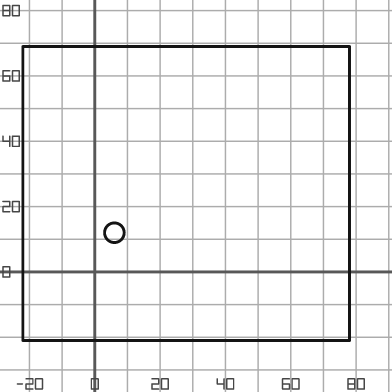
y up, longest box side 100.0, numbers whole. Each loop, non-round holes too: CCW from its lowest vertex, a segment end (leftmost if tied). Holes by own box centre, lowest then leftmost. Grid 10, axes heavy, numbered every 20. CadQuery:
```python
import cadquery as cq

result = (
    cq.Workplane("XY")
    .moveTo(-22.0, -21.0)
    .lineTo(78.0, -21.0)
    .lineTo(78.0, 69.0)
    .lineTo(-22.0, 69.0)
    .close()
    .moveTo(6.0, 12.0)
    .circle(3.0)
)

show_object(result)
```